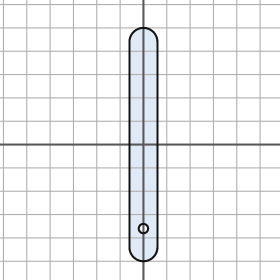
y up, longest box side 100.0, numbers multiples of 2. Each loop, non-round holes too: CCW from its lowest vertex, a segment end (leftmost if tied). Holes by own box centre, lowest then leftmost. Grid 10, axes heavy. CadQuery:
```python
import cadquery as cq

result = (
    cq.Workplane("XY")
    .moveTo(-6.0, -44.0)
    .threePointArc((0.0, -50.0), (6.0, -44.0))
    .lineTo(6.0, 44.0)
    .threePointArc((0.0, 50.0), (-6.0, 44.0))
    .close()
    .moveTo(0.0, -36.0)
    .circle(2.0)
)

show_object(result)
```